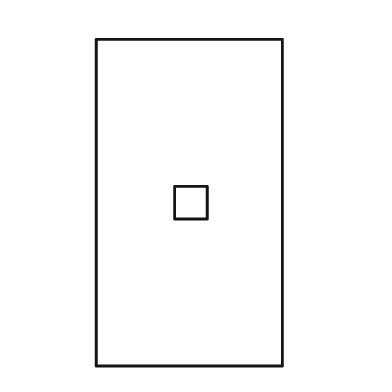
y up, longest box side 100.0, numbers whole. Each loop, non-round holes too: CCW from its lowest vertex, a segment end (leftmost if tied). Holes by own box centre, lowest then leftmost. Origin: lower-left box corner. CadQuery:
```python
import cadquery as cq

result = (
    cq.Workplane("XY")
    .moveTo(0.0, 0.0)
    .lineTo(57.0, 0.0)
    .lineTo(57.0, 100.0)
    .lineTo(0.0, 100.0)
    .close()
    .moveTo(24.0, 45.0)
    .lineTo(34.0, 45.0)
    .lineTo(34.0, 55.0)
    .lineTo(24.0, 55.0)
    .close()
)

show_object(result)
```